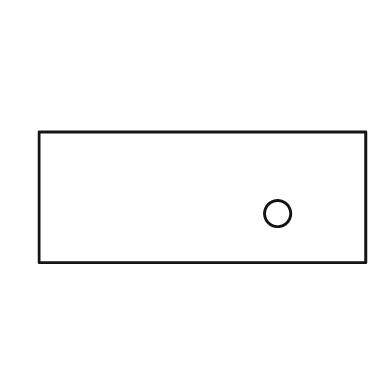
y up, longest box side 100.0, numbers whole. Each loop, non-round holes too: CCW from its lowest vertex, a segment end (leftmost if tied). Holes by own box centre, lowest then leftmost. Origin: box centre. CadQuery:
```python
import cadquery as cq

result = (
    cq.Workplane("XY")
    .moveTo(-50.0, -20.0)
    .lineTo(50.0, -20.0)
    .lineTo(50.0, 20.0)
    .lineTo(-50.0, 20.0)
    .close()
    .moveTo(23.0, -5.0)
    .circle(4.0)
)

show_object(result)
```